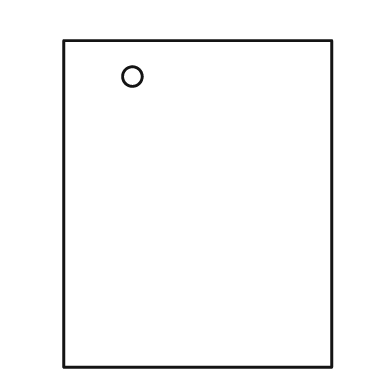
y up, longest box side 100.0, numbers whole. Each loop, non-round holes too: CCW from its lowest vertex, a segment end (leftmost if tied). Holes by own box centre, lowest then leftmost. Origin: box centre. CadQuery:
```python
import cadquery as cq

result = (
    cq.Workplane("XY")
    .moveTo(-41.0, -50.0)
    .lineTo(41.0, -50.0)
    .lineTo(41.0, 50.0)
    .lineTo(-41.0, 50.0)
    .close()
    .moveTo(-20.0, 39.0)
    .circle(3.0)
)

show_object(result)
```